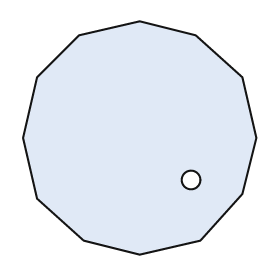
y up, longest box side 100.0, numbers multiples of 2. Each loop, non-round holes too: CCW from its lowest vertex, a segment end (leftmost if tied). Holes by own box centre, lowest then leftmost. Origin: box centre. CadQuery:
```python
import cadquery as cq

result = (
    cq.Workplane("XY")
    .moveTo(0.0, -50.0)
    .lineTo(26.0, -44.0)
    .lineTo(44.0, -24.0)
    .lineTo(50.0, 0.0)
    .lineTo(44.0, 26.0)
    .lineTo(24.0, 44.0)
    .lineTo(0.0, 50.0)
    .lineTo(-26.0, 44.0)
    .lineTo(-44.0, 26.0)
    .lineTo(-50.0, 0.0)
    .lineTo(-44.0, -26.0)
    .lineTo(-24.0, -44.0)
    .close()
    .moveTo(22.0, -18.0)
    .circle(4.0)
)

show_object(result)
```